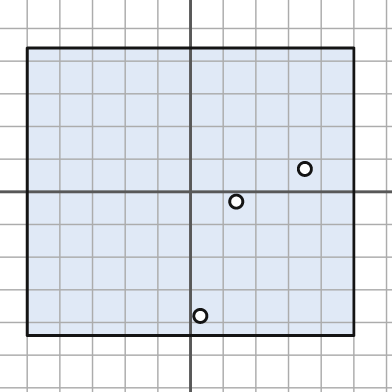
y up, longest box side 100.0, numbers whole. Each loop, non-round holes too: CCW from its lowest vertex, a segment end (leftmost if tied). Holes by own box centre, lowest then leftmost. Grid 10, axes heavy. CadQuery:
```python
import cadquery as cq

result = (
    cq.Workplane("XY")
    .moveTo(-50.0, -44.0)
    .lineTo(50.0, -44.0)
    .lineTo(50.0, 44.0)
    .lineTo(-50.0, 44.0)
    .close()
    .moveTo(3.0, -38.0)
    .circle(2.0)
    .moveTo(14.0, -3.0)
    .circle(2.0)
    .moveTo(35.0, 7.0)
    .circle(2.0)
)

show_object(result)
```